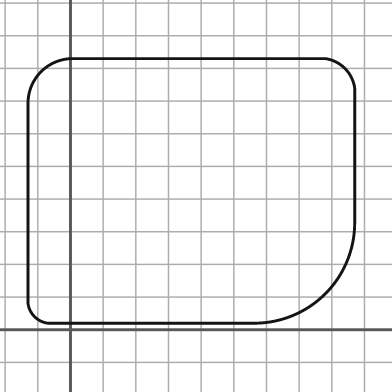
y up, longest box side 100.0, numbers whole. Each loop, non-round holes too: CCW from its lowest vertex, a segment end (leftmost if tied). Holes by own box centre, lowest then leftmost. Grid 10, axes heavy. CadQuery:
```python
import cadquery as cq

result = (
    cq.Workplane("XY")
    .moveTo(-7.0, 2.0)
    .lineTo(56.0, 2.0)
    .threePointArc((78.0, 11.0), (87.0, 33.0))
    .lineTo(87.0, 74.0)
    .threePointArc((84.0, 80.0), (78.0, 83.0))
    .lineTo(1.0, 83.0)
    .threePointArc((-9.0, 79.0), (-13.0, 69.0))
    .lineTo(-13.0, 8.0)
    .threePointArc((-11.0, 4.0), (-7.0, 2.0))
    .close()
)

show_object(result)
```